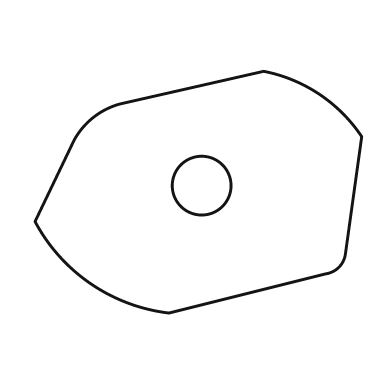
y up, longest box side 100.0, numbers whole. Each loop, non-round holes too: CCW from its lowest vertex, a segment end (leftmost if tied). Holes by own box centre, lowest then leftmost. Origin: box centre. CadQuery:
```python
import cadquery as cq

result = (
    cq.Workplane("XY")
    .moveTo(-9.0, -37.0)
    .lineTo(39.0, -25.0)
    .threePointArc((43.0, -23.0), (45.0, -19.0))
    .lineTo(50.0, 17.0)
    .threePointArc((37.0, 30.0), (20.0, 37.0))
    .lineTo(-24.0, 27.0)
    .threePointArc((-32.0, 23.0), (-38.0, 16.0))
    .lineTo(-50.0, -9.0)
    .threePointArc((-33.0, -28.0), (-9.0, -37.0))
    .close()
    .moveTo(1.0, 2.0)
    .circle(9.0)
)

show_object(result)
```